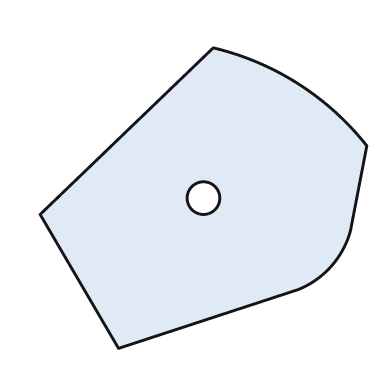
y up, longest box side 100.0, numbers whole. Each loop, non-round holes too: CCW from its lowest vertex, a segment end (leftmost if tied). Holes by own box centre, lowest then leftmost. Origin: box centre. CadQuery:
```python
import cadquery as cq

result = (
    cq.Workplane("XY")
    .moveTo(-26.0, -46.0)
    .lineTo(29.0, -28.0)
    .threePointArc((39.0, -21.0), (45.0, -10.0))
    .lineTo(50.0, 16.0)
    .threePointArc((29.0, 35.0), (3.0, 46.0))
    .lineTo(-50.0, -5.0)
    .close()
    .moveTo(0.0, 0.0)
    .circle(5.0)
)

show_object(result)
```